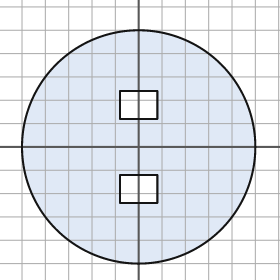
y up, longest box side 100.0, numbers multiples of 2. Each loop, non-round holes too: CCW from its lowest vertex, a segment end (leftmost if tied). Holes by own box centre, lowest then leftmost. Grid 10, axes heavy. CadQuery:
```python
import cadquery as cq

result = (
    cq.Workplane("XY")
    .moveTo(0.0, 0.0)
    .circle(50.0)
    .moveTo(-8.0, -24.0)
    .lineTo(8.0, -24.0)
    .lineTo(8.0, -12.0)
    .lineTo(-8.0, -12.0)
    .close()
    .moveTo(-8.0, 12.0)
    .lineTo(8.0, 12.0)
    .lineTo(8.0, 24.0)
    .lineTo(-8.0, 24.0)
    .close()
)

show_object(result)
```